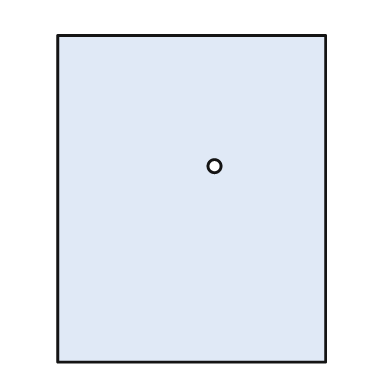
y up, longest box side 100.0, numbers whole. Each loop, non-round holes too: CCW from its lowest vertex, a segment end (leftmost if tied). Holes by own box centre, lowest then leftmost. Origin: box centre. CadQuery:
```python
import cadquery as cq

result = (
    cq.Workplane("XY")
    .moveTo(-41.0, -50.0)
    .lineTo(41.0, -50.0)
    .lineTo(41.0, 50.0)
    .lineTo(-41.0, 50.0)
    .close()
    .moveTo(7.0, 10.0)
    .circle(2.0)
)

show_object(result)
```